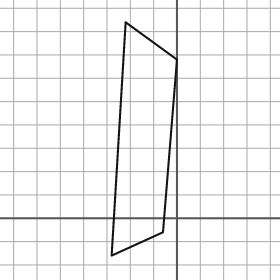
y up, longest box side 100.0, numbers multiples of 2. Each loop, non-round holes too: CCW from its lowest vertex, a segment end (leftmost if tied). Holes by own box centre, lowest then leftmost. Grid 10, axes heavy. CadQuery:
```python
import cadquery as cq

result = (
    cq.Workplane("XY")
    .moveTo(-28.0, -16.0)
    .lineTo(-6.0, -6.0)
    .lineTo(0.0, 68.0)
    .lineTo(-22.0, 84.0)
    .close()
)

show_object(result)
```